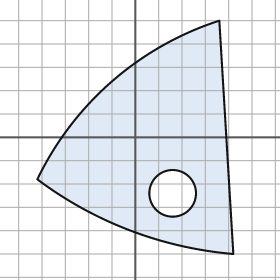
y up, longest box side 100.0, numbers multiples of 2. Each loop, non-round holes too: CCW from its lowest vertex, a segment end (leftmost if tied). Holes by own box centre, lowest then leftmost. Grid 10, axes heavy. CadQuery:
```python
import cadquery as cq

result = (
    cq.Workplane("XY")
    .moveTo(42.0, -50.0)
    .lineTo(36.0, 50.0)
    .threePointArc((-10.0, 24.0), (-42.0, -18.0))
    .threePointArc((-2.0, -40.0), (42.0, -50.0))
    .close()
    .moveTo(16.0, -24.0)
    .circle(10.0)
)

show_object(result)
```